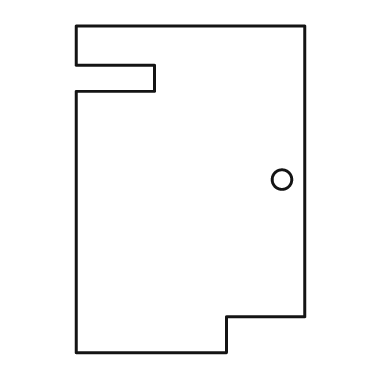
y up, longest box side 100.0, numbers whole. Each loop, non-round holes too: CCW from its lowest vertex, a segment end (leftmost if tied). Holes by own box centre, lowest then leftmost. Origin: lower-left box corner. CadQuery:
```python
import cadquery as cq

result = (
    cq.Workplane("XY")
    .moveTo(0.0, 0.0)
    .lineTo(46.0, 0.0)
    .lineTo(46.0, 11.0)
    .lineTo(70.0, 11.0)
    .lineTo(70.0, 100.0)
    .lineTo(0.0, 100.0)
    .lineTo(0.0, 88.0)
    .lineTo(24.0, 88.0)
    .lineTo(24.0, 80.0)
    .lineTo(0.0, 80.0)
    .close()
    .moveTo(63.0, 53.0)
    .circle(3.0)
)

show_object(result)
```